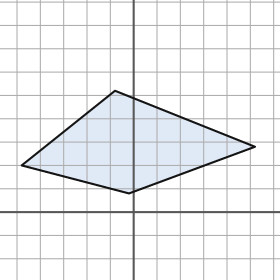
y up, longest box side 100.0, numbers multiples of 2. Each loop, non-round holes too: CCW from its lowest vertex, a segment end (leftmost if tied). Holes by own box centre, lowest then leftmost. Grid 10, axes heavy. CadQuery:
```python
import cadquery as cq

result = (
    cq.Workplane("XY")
    .moveTo(-2.0, 8.0)
    .lineTo(52.0, 28.0)
    .lineTo(-8.0, 52.0)
    .lineTo(-48.0, 20.0)
    .close()
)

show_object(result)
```